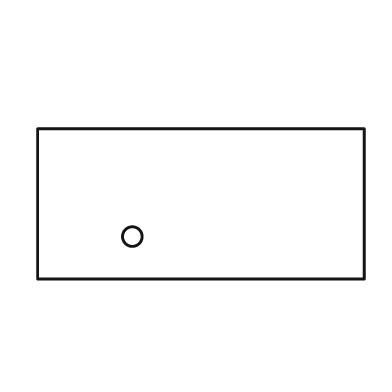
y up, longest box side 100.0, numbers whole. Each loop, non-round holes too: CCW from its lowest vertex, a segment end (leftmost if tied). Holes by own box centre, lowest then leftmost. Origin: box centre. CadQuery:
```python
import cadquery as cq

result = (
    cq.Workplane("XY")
    .moveTo(-50.0, -23.0)
    .lineTo(50.0, -23.0)
    .lineTo(50.0, 23.0)
    .lineTo(-50.0, 23.0)
    .close()
    .moveTo(-21.0, -10.0)
    .circle(3.0)
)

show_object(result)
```